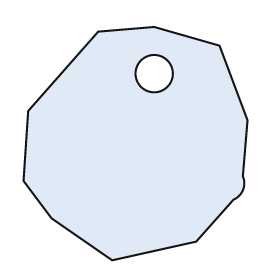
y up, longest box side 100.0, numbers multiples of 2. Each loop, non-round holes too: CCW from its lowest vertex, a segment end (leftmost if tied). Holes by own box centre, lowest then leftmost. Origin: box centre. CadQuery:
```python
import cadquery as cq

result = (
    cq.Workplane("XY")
    .moveTo(-10.0, -50.0)
    .lineTo(26.0, -42.0)
    .lineTo(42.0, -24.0)
    .threePointArc((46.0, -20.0), (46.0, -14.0))
    .lineTo(48.0, 10.0)
    .lineTo(36.0, 42.0)
    .lineTo(8.0, 50.0)
    .lineTo(-16.0, 48.0)
    .lineTo(-46.0, 14.0)
    .lineTo(-48.0, -16.0)
    .lineTo(-36.0, -32.0)
    .close()
    .moveTo(8.0, 30.0)
    .circle(8.0)
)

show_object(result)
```